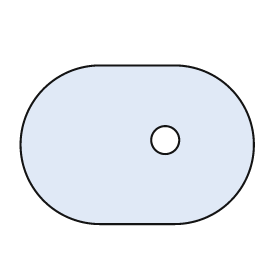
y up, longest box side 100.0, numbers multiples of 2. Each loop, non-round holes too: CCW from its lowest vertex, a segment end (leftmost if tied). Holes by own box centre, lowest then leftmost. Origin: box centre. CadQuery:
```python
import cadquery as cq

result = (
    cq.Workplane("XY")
    .moveTo(-16.0, -34.0)
    .lineTo(16.0, -34.0)
    .threePointArc((50.0, 0.0), (16.0, 34.0))
    .lineTo(-16.0, 34.0)
    .threePointArc((-50.0, 0.0), (-16.0, -34.0))
    .close()
    .moveTo(12.0, 2.0)
    .circle(6.0)
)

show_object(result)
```